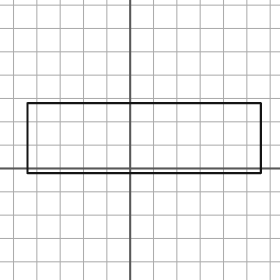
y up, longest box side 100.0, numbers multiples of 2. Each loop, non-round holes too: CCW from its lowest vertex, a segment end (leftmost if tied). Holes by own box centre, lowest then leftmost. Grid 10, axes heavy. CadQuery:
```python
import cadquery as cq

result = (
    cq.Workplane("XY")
    .moveTo(-44.0, -2.0)
    .lineTo(56.0, -2.0)
    .lineTo(56.0, 28.0)
    .lineTo(-44.0, 28.0)
    .close()
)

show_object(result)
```